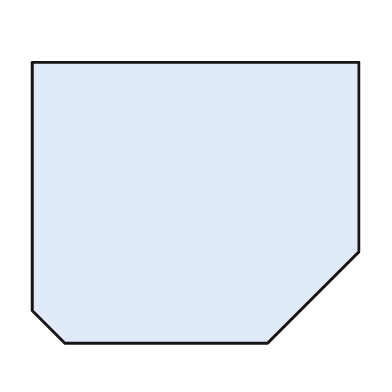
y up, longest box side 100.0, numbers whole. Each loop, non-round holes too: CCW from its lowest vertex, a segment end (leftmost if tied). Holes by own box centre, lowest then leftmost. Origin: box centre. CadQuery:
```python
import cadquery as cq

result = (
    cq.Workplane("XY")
    .moveTo(-40.0, -43.0)
    .lineTo(22.0, -43.0)
    .lineTo(50.0, -15.0)
    .lineTo(50.0, 43.0)
    .lineTo(-50.0, 43.0)
    .lineTo(-50.0, -33.0)
    .close()
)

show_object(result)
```